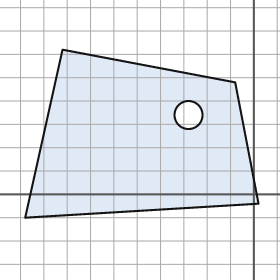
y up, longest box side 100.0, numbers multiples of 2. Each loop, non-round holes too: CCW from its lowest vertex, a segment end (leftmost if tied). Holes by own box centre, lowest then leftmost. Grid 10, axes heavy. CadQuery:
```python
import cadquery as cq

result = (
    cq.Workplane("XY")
    .moveTo(-98.0, -10.0)
    .lineTo(2.0, -4.0)
    .lineTo(-8.0, 48.0)
    .lineTo(-82.0, 62.0)
    .close()
    .moveTo(-28.0, 34.0)
    .circle(6.0)
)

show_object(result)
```